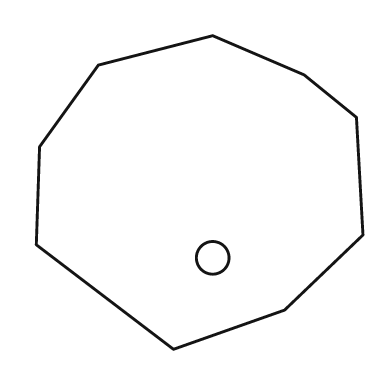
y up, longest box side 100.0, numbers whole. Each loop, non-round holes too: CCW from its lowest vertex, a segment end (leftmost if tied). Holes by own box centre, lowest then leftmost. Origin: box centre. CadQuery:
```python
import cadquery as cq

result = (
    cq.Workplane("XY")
    .moveTo(-8.0, -48.0)
    .lineTo(26.0, -36.0)
    .lineTo(50.0, -13.0)
    .lineTo(48.0, 23.0)
    .lineTo(32.0, 36.0)
    .lineTo(4.0, 48.0)
    .lineTo(-31.0, 39.0)
    .lineTo(-49.0, 14.0)
    .lineTo(-50.0, -16.0)
    .close()
    .moveTo(4.0, -20.0)
    .circle(5.0)
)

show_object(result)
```